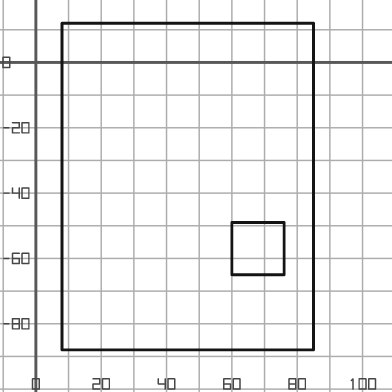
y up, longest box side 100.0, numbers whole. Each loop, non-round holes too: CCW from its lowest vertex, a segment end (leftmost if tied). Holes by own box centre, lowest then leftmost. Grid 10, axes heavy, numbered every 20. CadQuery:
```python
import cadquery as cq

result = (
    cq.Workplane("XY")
    .moveTo(8.0, -88.0)
    .lineTo(85.0, -88.0)
    .lineTo(85.0, 12.0)
    .lineTo(8.0, 12.0)
    .close()
    .moveTo(60.0, -65.0)
    .lineTo(76.0, -65.0)
    .lineTo(76.0, -49.0)
    .lineTo(60.0, -49.0)
    .close()
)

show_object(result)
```